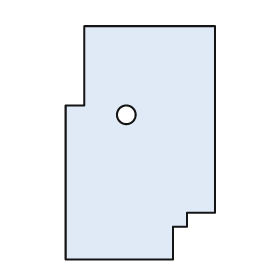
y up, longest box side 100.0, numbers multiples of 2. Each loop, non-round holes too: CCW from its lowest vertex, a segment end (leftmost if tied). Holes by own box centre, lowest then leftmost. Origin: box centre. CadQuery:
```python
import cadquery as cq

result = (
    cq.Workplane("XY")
    .moveTo(-32.0, -50.0)
    .lineTo(14.0, -50.0)
    .lineTo(14.0, -36.0)
    .lineTo(20.0, -36.0)
    .lineTo(20.0, -30.0)
    .lineTo(32.0, -30.0)
    .lineTo(32.0, 50.0)
    .lineTo(-24.0, 50.0)
    .lineTo(-24.0, 16.0)
    .lineTo(-32.0, 16.0)
    .close()
    .moveTo(-6.0, 12.0)
    .circle(4.0)
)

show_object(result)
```